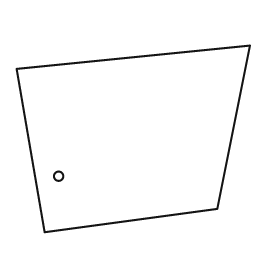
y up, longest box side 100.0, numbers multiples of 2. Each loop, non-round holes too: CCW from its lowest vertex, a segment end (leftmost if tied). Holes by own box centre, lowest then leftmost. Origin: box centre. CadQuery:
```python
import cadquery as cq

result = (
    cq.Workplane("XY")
    .moveTo(-38.0, -40.0)
    .lineTo(36.0, -30.0)
    .lineTo(50.0, 40.0)
    .lineTo(-50.0, 30.0)
    .close()
    .moveTo(-32.0, -16.0)
    .circle(2.0)
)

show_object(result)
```